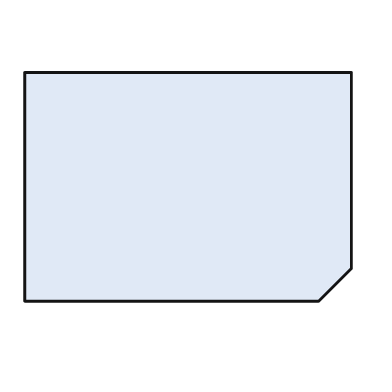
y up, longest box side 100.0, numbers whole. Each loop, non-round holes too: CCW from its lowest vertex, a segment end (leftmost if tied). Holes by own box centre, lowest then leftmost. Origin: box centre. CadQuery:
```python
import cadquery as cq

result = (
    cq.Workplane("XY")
    .moveTo(-50.0, -35.0)
    .lineTo(40.0, -35.0)
    .lineTo(50.0, -25.0)
    .lineTo(50.0, 35.0)
    .lineTo(-50.0, 35.0)
    .close()
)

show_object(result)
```